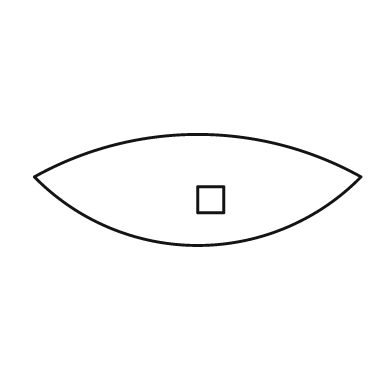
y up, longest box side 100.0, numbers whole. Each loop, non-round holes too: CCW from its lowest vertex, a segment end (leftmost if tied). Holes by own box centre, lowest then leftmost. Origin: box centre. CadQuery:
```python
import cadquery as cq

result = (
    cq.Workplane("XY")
    .moveTo(-50.0, 4.0)
    .threePointArc((0.0, -17.0), (50.0, 4.0))
    .threePointArc((0.0, 17.0), (-50.0, 4.0))
    .close()
    .moveTo(0.0, -7.0)
    .lineTo(8.0, -7.0)
    .lineTo(8.0, 1.0)
    .lineTo(0.0, 1.0)
    .close()
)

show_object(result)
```